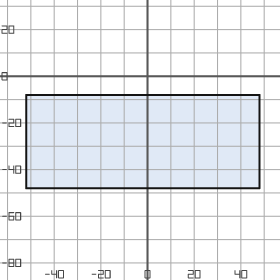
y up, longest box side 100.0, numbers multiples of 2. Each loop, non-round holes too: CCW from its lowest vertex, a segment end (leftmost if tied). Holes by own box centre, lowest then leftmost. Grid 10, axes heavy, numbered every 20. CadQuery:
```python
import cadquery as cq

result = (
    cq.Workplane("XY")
    .moveTo(-52.0, -48.0)
    .lineTo(48.0, -48.0)
    .lineTo(48.0, -8.0)
    .lineTo(-52.0, -8.0)
    .close()
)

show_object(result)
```